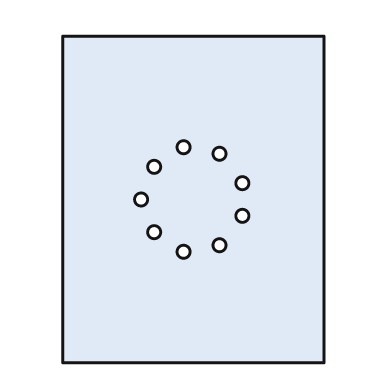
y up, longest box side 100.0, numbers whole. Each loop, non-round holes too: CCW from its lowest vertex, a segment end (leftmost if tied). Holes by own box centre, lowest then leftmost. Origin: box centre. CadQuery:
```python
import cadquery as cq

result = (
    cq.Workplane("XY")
    .moveTo(-40.0, -50.0)
    .lineTo(40.0, -50.0)
    .lineTo(40.0, 50.0)
    .lineTo(-40.0, 50.0)
    .close()
    .moveTo(-3.0, -16.0)
    .circle(2.0)
    .moveTo(8.0, -14.0)
    .circle(2.0)
    .moveTo(-12.0, -10.0)
    .circle(2.0)
    .moveTo(15.0, -5.0)
    .circle(2.0)
    .moveTo(-16.0, 0.0)
    .circle(2.0)
    .moveTo(15.0, 5.0)
    .circle(2.0)
    .moveTo(-12.0, 10.0)
    .circle(2.0)
    .moveTo(8.0, 14.0)
    .circle(2.0)
    .moveTo(-3.0, 16.0)
    .circle(2.0)
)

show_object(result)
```